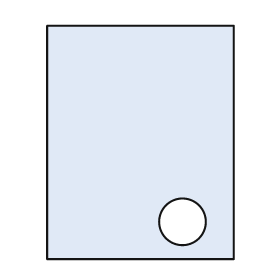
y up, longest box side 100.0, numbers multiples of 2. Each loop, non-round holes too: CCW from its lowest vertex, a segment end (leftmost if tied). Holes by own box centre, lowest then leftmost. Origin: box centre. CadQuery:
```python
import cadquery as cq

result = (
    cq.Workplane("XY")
    .moveTo(-40.0, -50.0)
    .lineTo(40.0, -50.0)
    .lineTo(40.0, 50.0)
    .lineTo(-40.0, 50.0)
    .close()
    .moveTo(18.0, -34.0)
    .circle(10.0)
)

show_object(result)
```